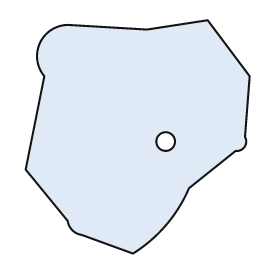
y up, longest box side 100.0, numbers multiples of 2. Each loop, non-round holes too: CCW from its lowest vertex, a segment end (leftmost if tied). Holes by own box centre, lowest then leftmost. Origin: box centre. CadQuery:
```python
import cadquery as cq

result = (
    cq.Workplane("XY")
    .moveTo(-2.0, -50.0)
    .threePointArc((12.0, -38.0), (22.0, -22.0))
    .lineTo(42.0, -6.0)
    .threePointArc((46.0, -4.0), (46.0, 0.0))
    .lineTo(48.0, 26.0)
    .lineTo(30.0, 50.0)
    .lineTo(4.0, 46.0)
    .lineTo(-30.0, 48.0)
    .threePointArc((-42.0, 40.0), (-40.0, 26.0))
    .lineTo(-48.0, -14.0)
    .lineTo(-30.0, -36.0)
    .threePointArc((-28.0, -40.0), (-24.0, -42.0))
    .close()
    .moveTo(12.0, -2.0)
    .circle(4.0)
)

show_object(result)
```